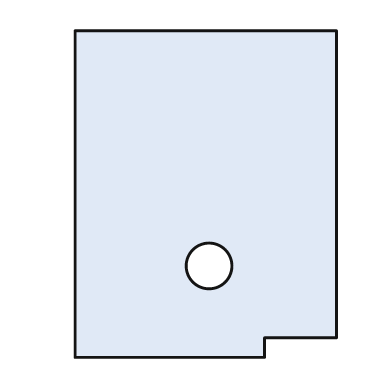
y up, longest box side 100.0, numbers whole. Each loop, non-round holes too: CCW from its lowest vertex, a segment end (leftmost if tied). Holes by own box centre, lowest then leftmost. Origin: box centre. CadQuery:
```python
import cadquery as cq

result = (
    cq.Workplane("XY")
    .moveTo(-40.0, -50.0)
    .lineTo(18.0, -50.0)
    .lineTo(18.0, -44.0)
    .lineTo(40.0, -44.0)
    .lineTo(40.0, 50.0)
    .lineTo(-40.0, 50.0)
    .close()
    .moveTo(1.0, -22.0)
    .circle(7.0)
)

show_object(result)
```